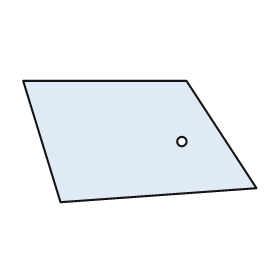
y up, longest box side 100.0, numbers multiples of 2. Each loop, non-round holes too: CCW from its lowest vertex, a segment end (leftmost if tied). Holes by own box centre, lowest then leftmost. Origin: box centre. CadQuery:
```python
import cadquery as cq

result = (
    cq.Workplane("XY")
    .moveTo(-34.0, -26.0)
    .lineTo(50.0, -20.0)
    .lineTo(20.0, 26.0)
    .lineTo(-50.0, 26.0)
    .close()
    .moveTo(18.0, 0.0)
    .circle(2.0)
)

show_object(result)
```